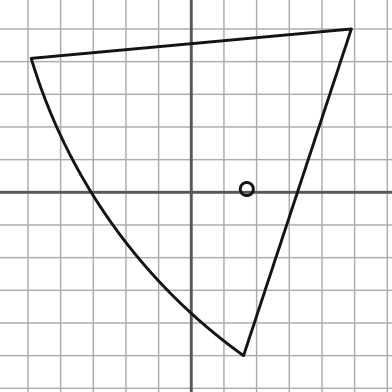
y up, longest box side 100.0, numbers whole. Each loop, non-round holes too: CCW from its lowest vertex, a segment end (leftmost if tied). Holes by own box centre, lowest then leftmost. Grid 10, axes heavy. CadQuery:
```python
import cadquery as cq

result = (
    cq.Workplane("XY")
    .moveTo(16.0, -50.0)
    .lineTo(49.0, 50.0)
    .lineTo(-49.0, 41.0)
    .threePointArc((-24.0, -10.0), (16.0, -50.0))
    .close()
    .moveTo(17.0, 1.0)
    .circle(2.0)
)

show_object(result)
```